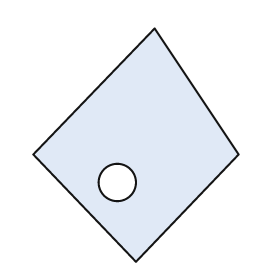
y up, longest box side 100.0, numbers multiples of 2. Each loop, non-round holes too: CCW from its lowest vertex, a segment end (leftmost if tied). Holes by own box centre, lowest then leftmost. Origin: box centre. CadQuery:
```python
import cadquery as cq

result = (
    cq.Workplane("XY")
    .moveTo(0.0, -50.0)
    .lineTo(44.0, -4.0)
    .lineTo(8.0, 50.0)
    .lineTo(-44.0, -4.0)
    .close()
    .moveTo(-8.0, -16.0)
    .circle(8.0)
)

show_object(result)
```